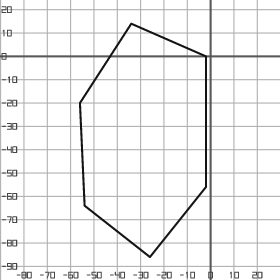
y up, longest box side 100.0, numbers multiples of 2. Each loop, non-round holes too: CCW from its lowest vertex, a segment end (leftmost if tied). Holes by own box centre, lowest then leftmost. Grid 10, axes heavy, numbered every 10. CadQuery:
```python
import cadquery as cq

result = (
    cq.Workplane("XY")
    .moveTo(-26.0, -86.0)
    .lineTo(-2.0, -56.0)
    .lineTo(-2.0, 0.0)
    .lineTo(-34.0, 14.0)
    .lineTo(-56.0, -20.0)
    .lineTo(-54.0, -64.0)
    .close()
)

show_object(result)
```